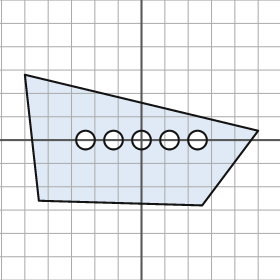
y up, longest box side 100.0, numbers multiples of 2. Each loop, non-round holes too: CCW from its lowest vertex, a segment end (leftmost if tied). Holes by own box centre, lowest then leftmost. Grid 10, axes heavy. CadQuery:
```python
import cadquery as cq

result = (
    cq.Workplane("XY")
    .moveTo(26.0, -28.0)
    .lineTo(50.0, 4.0)
    .lineTo(-50.0, 28.0)
    .lineTo(-44.0, -26.0)
    .close()
    .moveTo(-24.0, 0.0)
    .circle(4.0)
    .moveTo(-12.0, 0.0)
    .circle(4.0)
    .moveTo(0.0, 0.0)
    .circle(4.0)
    .moveTo(12.0, 0.0)
    .circle(4.0)
    .moveTo(24.0, 0.0)
    .circle(4.0)
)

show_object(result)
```